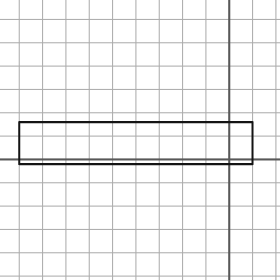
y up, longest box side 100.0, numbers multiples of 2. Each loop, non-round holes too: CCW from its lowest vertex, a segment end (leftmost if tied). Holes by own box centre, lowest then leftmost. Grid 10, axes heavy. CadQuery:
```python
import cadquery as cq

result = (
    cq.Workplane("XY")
    .moveTo(-90.0, -2.0)
    .lineTo(10.0, -2.0)
    .lineTo(10.0, 16.0)
    .lineTo(-90.0, 16.0)
    .close()
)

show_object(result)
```